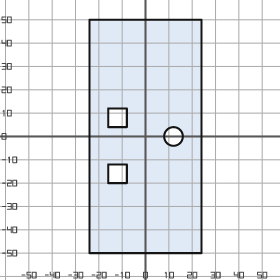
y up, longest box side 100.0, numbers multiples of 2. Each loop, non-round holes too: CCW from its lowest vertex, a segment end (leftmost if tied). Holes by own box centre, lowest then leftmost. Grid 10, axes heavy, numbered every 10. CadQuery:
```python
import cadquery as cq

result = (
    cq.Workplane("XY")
    .moveTo(-24.0, -50.0)
    .lineTo(24.0, -50.0)
    .lineTo(24.0, 50.0)
    .lineTo(-24.0, 50.0)
    .close()
    .moveTo(-16.0, -20.0)
    .lineTo(-8.0, -20.0)
    .lineTo(-8.0, -12.0)
    .lineTo(-16.0, -12.0)
    .close()
    .moveTo(12.0, 0.0)
    .circle(4.0)
    .moveTo(-16.0, 4.0)
    .lineTo(-8.0, 4.0)
    .lineTo(-8.0, 12.0)
    .lineTo(-16.0, 12.0)
    .close()
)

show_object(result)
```